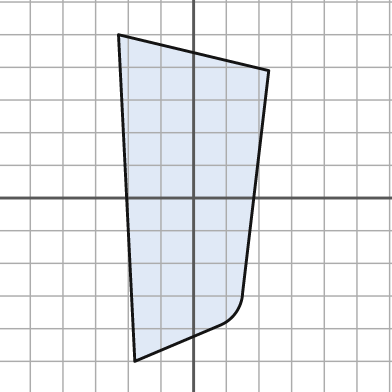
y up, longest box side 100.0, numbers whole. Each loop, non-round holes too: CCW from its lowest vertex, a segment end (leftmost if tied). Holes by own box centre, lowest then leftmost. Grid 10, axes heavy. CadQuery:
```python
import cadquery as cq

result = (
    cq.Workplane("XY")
    .moveTo(-18.0, -50.0)
    .lineTo(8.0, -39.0)
    .threePointArc((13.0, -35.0), (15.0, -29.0))
    .lineTo(23.0, 39.0)
    .lineTo(-23.0, 50.0)
    .close()
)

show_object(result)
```